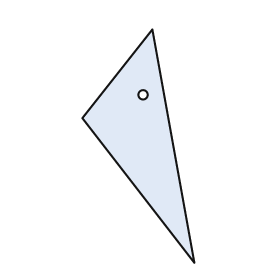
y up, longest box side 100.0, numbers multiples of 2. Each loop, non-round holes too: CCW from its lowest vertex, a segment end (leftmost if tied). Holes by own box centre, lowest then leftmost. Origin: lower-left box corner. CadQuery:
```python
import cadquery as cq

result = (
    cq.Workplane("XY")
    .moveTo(48.0, 0.0)
    .lineTo(30.0, 100.0)
    .lineTo(0.0, 62.0)
    .close()
    .moveTo(26.0, 72.0)
    .circle(2.0)
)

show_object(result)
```